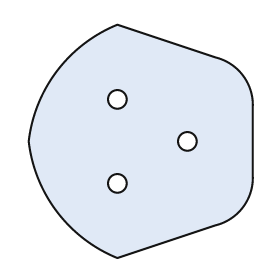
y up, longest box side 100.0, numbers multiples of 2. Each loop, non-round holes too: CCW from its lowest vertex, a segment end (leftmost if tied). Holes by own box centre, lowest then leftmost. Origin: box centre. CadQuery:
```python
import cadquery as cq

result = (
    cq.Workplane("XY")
    .moveTo(-10.0, -50.0)
    .lineTo(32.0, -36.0)
    .threePointArc((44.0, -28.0), (48.0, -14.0))
    .lineTo(48.0, 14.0)
    .threePointArc((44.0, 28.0), (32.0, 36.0))
    .lineTo(-10.0, 50.0)
    .threePointArc((-36.0, 30.0), (-48.0, 0.0))
    .threePointArc((-36.0, -30.0), (-10.0, -50.0))
    .close()
    .moveTo(-10.0, -18.0)
    .circle(4.0)
    .moveTo(20.0, 0.0)
    .circle(4.0)
    .moveTo(-10.0, 18.0)
    .circle(4.0)
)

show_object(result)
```